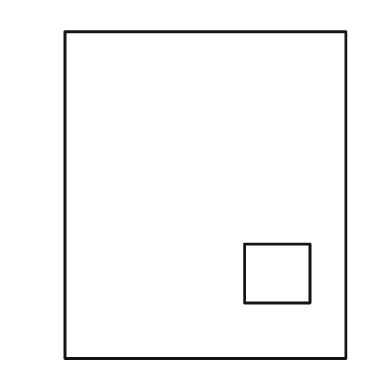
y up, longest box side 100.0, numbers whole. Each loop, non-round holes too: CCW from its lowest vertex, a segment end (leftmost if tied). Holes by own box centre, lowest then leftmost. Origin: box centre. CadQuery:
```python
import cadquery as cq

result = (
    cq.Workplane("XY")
    .moveTo(-43.0, -50.0)
    .lineTo(43.0, -50.0)
    .lineTo(43.0, 50.0)
    .lineTo(-43.0, 50.0)
    .close()
    .moveTo(12.0, -33.0)
    .lineTo(32.0, -33.0)
    .lineTo(32.0, -15.0)
    .lineTo(12.0, -15.0)
    .close()
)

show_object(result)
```